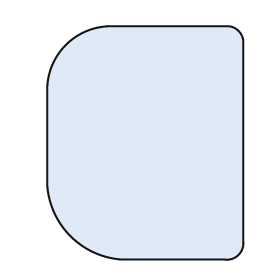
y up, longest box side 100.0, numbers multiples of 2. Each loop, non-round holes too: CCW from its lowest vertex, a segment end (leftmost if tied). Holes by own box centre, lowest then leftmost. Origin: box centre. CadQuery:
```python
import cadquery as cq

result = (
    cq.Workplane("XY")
    .moveTo(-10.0, -50.0)
    .lineTo(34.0, -50.0)
    .threePointArc((40.0, -48.0), (42.0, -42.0))
    .lineTo(42.0, 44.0)
    .threePointArc((40.0, 48.0), (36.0, 50.0))
    .lineTo(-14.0, 50.0)
    .threePointArc((-34.0, 42.0), (-42.0, 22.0))
    .lineTo(-42.0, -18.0)
    .threePointArc((-32.0, -40.0), (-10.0, -50.0))
    .close()
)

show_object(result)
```